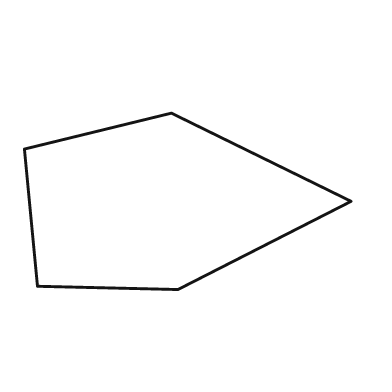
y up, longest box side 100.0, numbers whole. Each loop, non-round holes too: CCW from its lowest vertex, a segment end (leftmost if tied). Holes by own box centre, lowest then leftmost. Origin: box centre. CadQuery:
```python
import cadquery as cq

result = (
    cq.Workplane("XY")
    .moveTo(-3.0, -27.0)
    .lineTo(50.0, 0.0)
    .lineTo(-5.0, 27.0)
    .lineTo(-50.0, 16.0)
    .lineTo(-46.0, -26.0)
    .close()
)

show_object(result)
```